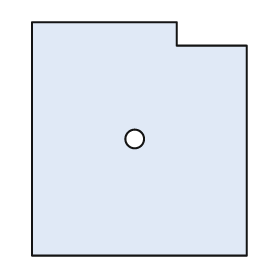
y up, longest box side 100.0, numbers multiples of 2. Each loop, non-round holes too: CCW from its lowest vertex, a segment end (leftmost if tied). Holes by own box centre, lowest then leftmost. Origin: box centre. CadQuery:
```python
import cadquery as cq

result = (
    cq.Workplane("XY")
    .moveTo(-46.0, -50.0)
    .lineTo(46.0, -50.0)
    .lineTo(46.0, 40.0)
    .lineTo(16.0, 40.0)
    .lineTo(16.0, 50.0)
    .lineTo(-46.0, 50.0)
    .close()
    .moveTo(-2.0, 0.0)
    .circle(4.0)
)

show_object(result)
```